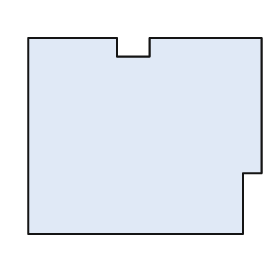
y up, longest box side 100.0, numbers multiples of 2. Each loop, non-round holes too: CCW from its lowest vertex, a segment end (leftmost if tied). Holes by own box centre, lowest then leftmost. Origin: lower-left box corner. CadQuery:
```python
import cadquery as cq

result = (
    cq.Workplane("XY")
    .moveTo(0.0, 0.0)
    .lineTo(92.0, 0.0)
    .lineTo(92.0, 26.0)
    .lineTo(100.0, 26.0)
    .lineTo(100.0, 84.0)
    .lineTo(52.0, 84.0)
    .lineTo(52.0, 76.0)
    .lineTo(38.0, 76.0)
    .lineTo(38.0, 84.0)
    .lineTo(0.0, 84.0)
    .close()
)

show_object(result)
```